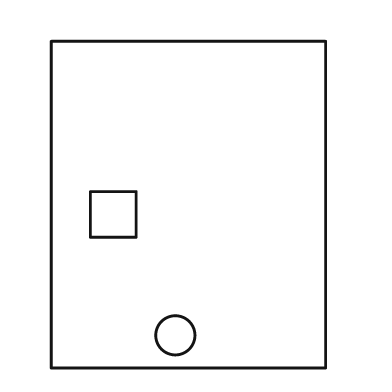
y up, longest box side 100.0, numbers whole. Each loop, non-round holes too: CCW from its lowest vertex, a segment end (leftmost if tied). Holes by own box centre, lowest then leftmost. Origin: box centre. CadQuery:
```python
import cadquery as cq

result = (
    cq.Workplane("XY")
    .moveTo(-42.0, -50.0)
    .lineTo(42.0, -50.0)
    .lineTo(42.0, 50.0)
    .lineTo(-42.0, 50.0)
    .close()
    .moveTo(-4.0, -40.0)
    .circle(6.0)
    .moveTo(-30.0, -10.0)
    .lineTo(-16.0, -10.0)
    .lineTo(-16.0, 4.0)
    .lineTo(-30.0, 4.0)
    .close()
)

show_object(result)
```